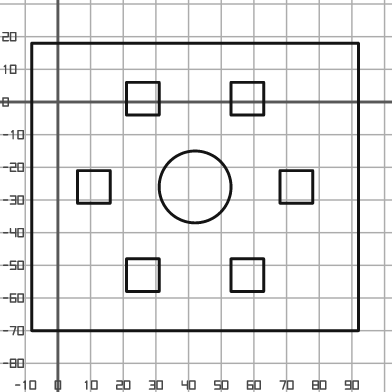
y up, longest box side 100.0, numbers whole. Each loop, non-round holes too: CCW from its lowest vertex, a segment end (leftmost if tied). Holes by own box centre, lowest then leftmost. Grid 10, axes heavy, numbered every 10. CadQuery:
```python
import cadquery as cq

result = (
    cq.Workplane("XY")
    .moveTo(-8.0, -70.0)
    .lineTo(92.0, -70.0)
    .lineTo(92.0, 18.0)
    .lineTo(-8.0, 18.0)
    .close()
    .moveTo(21.0, -58.0)
    .lineTo(31.0, -58.0)
    .lineTo(31.0, -48.0)
    .lineTo(21.0, -48.0)
    .close()
    .moveTo(53.0, -58.0)
    .lineTo(63.0, -58.0)
    .lineTo(63.0, -48.0)
    .lineTo(53.0, -48.0)
    .close()
    .moveTo(6.0, -31.0)
    .lineTo(16.0, -31.0)
    .lineTo(16.0, -21.0)
    .lineTo(6.0, -21.0)
    .close()
    .moveTo(42.0, -26.0)
    .circle(11.0)
    .moveTo(68.0, -31.0)
    .lineTo(78.0, -31.0)
    .lineTo(78.0, -21.0)
    .lineTo(68.0, -21.0)
    .close()
    .moveTo(21.0, -4.0)
    .lineTo(31.0, -4.0)
    .lineTo(31.0, 6.0)
    .lineTo(21.0, 6.0)
    .close()
    .moveTo(53.0, -4.0)
    .lineTo(63.0, -4.0)
    .lineTo(63.0, 6.0)
    .lineTo(53.0, 6.0)
    .close()
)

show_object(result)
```